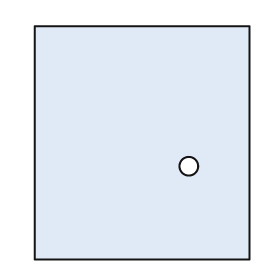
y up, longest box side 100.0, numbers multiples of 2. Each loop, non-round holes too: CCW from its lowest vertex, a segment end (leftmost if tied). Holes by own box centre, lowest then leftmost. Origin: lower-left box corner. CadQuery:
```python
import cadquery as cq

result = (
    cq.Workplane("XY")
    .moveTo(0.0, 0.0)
    .lineTo(92.0, 0.0)
    .lineTo(92.0, 100.0)
    .lineTo(0.0, 100.0)
    .close()
    .moveTo(66.0, 40.0)
    .circle(4.0)
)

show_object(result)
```